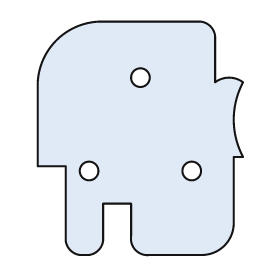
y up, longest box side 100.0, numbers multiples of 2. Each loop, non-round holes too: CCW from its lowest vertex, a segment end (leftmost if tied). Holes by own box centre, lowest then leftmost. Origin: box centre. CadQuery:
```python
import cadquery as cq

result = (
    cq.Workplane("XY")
    .moveTo(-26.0, -50.0)
    .lineTo(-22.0, -50.0)
    .threePointArc((-18.0, -48.0), (-16.0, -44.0))
    .lineTo(-16.0, -28.0)
    .lineTo(-4.0, -28.0)
    .lineTo(-4.0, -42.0)
    .threePointArc((-2.0, -48.0), (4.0, -50.0))
    .lineTo(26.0, -50.0)
    .threePointArc((36.0, -46.0), (40.0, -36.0))
    .lineTo(40.0, -8.0)
    .lineTo(44.0, -8.0)
    .threePointArc((40.0, 8.0), (44.0, 24.0))
    .threePointArc((38.0, 26.0), (32.0, 24.0))
    .lineTo(32.0, 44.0)
    .threePointArc((30.0, 48.0), (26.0, 50.0))
    .lineTo(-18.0, 50.0)
    .threePointArc((-36.0, 42.0), (-44.0, 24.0))
    .lineTo(-44.0, -12.0)
    .lineTo(-32.0, -12.0)
    .lineTo(-32.0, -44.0)
    .threePointArc((-30.0, -48.0), (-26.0, -50.0))
    .close()
    .moveTo(-22.0, -14.0)
    .circle(4.0)
    .moveTo(22.0, -14.0)
    .circle(4.0)
    .moveTo(0.0, 26.0)
    .circle(4.0)
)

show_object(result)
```